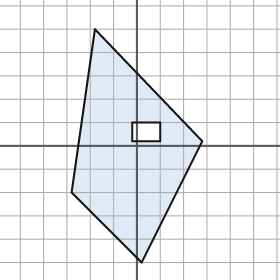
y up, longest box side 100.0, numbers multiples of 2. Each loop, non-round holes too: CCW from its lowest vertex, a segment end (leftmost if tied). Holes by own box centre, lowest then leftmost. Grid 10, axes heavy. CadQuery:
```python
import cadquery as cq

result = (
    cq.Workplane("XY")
    .moveTo(2.0, -50.0)
    .lineTo(28.0, 2.0)
    .lineTo(-18.0, 50.0)
    .lineTo(-28.0, -20.0)
    .close()
    .moveTo(-2.0, 2.0)
    .lineTo(10.0, 2.0)
    .lineTo(10.0, 10.0)
    .lineTo(-2.0, 10.0)
    .close()
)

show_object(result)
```